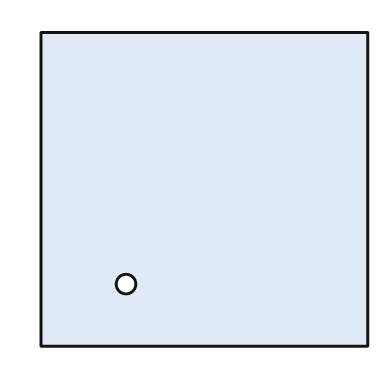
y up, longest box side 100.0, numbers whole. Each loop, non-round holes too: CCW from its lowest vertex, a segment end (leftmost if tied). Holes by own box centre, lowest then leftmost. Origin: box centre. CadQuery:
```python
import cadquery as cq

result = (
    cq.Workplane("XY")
    .moveTo(-50.0, -48.0)
    .lineTo(50.0, -48.0)
    .lineTo(50.0, 48.0)
    .lineTo(-50.0, 48.0)
    .close()
    .moveTo(-24.0, -29.0)
    .circle(3.0)
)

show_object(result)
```